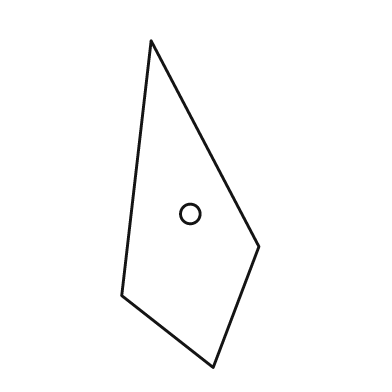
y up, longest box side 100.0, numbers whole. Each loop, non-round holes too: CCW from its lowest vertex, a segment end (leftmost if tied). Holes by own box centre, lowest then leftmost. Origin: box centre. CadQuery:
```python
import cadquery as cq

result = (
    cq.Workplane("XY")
    .moveTo(7.0, -50.0)
    .lineTo(21.0, -13.0)
    .lineTo(-12.0, 50.0)
    .lineTo(-21.0, -28.0)
    .close()
    .moveTo(0.0, -3.0)
    .circle(3.0)
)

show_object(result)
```